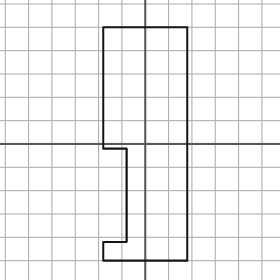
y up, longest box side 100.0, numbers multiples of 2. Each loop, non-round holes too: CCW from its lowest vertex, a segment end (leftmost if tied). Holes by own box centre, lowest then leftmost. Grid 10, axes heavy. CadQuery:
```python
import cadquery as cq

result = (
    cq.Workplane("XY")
    .moveTo(-18.0, -50.0)
    .lineTo(18.0, -50.0)
    .lineTo(18.0, 50.0)
    .lineTo(-18.0, 50.0)
    .lineTo(-18.0, -2.0)
    .lineTo(-8.0, -2.0)
    .lineTo(-8.0, -42.0)
    .lineTo(-18.0, -42.0)
    .close()
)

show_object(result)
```